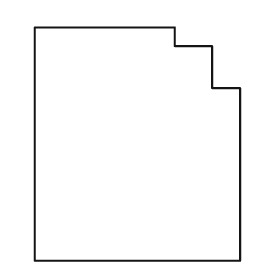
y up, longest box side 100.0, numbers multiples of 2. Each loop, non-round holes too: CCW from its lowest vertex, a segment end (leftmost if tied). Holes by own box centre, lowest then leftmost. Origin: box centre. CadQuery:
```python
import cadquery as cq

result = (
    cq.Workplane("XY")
    .moveTo(-44.0, -50.0)
    .lineTo(44.0, -50.0)
    .lineTo(44.0, 24.0)
    .lineTo(32.0, 24.0)
    .lineTo(32.0, 42.0)
    .lineTo(16.0, 42.0)
    .lineTo(16.0, 50.0)
    .lineTo(-44.0, 50.0)
    .close()
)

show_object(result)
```